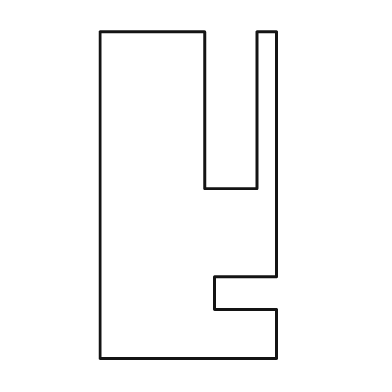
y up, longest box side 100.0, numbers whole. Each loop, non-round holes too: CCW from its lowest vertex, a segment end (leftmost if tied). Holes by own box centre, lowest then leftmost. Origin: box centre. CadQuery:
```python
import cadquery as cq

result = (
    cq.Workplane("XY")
    .moveTo(-27.0, -50.0)
    .lineTo(27.0, -50.0)
    .lineTo(27.0, -35.0)
    .lineTo(8.0, -35.0)
    .lineTo(8.0, -25.0)
    .lineTo(27.0, -25.0)
    .lineTo(27.0, 50.0)
    .lineTo(21.0, 50.0)
    .lineTo(21.0, 2.0)
    .lineTo(5.0, 2.0)
    .lineTo(5.0, 50.0)
    .lineTo(-27.0, 50.0)
    .close()
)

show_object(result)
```